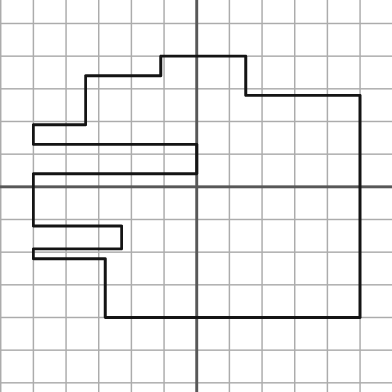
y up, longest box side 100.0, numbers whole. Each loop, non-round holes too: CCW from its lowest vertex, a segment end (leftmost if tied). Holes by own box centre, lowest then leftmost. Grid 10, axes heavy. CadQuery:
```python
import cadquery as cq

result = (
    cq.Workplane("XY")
    .moveTo(-28.0, -40.0)
    .lineTo(50.0, -40.0)
    .lineTo(50.0, 28.0)
    .lineTo(15.0, 28.0)
    .lineTo(15.0, 40.0)
    .lineTo(-11.0, 40.0)
    .lineTo(-11.0, 34.0)
    .lineTo(-34.0, 34.0)
    .lineTo(-34.0, 19.0)
    .lineTo(-50.0, 19.0)
    .lineTo(-50.0, 13.0)
    .lineTo(0.0, 13.0)
    .lineTo(0.0, 4.0)
    .lineTo(-50.0, 4.0)
    .lineTo(-50.0, -12.0)
    .lineTo(-23.0, -12.0)
    .lineTo(-23.0, -19.0)
    .lineTo(-50.0, -19.0)
    .lineTo(-50.0, -22.0)
    .lineTo(-28.0, -22.0)
    .close()
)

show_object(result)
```